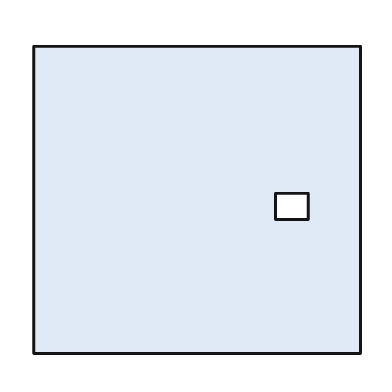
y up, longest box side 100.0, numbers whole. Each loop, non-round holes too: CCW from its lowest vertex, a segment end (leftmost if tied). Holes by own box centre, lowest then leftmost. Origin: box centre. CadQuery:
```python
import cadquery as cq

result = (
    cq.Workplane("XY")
    .moveTo(-50.0, -47.0)
    .lineTo(50.0, -47.0)
    .lineTo(50.0, 47.0)
    .lineTo(-50.0, 47.0)
    .close()
    .moveTo(24.0, -6.0)
    .lineTo(34.0, -6.0)
    .lineTo(34.0, 2.0)
    .lineTo(24.0, 2.0)
    .close()
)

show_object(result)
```